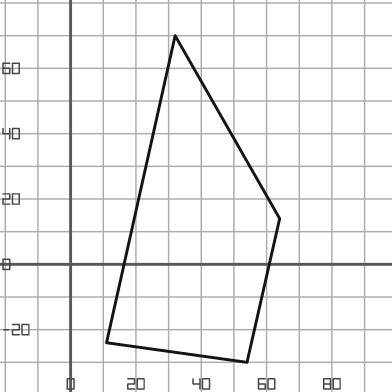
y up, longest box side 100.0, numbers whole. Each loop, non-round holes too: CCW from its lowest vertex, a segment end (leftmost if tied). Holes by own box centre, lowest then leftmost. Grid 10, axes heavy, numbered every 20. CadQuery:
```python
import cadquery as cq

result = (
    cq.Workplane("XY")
    .moveTo(54.0, -30.0)
    .lineTo(64.0, 14.0)
    .lineTo(32.0, 70.0)
    .lineTo(11.0, -24.0)
    .close()
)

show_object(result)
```